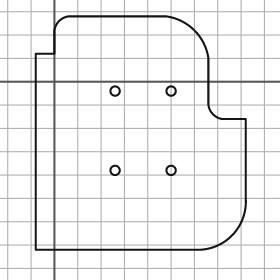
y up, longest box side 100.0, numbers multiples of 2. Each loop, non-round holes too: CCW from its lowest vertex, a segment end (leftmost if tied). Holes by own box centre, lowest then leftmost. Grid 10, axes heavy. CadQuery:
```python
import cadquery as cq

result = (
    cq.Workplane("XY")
    .moveTo(-8.0, -72.0)
    .lineTo(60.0, -72.0)
    .threePointArc((76.0, -66.0), (82.0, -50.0))
    .lineTo(82.0, -16.0)
    .lineTo(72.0, -16.0)
    .threePointArc((68.0, -14.0), (66.0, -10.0))
    .lineTo(66.0, 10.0)
    .threePointArc((60.0, 22.0), (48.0, 28.0))
    .lineTo(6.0, 28.0)
    .threePointArc((2.0, 26.0), (0.0, 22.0))
    .lineTo(0.0, 12.0)
    .lineTo(-8.0, 12.0)
    .close()
    .moveTo(26.0, -38.0)
    .circle(2.0)
    .moveTo(50.0, -38.0)
    .circle(2.0)
    .moveTo(26.0, -4.0)
    .circle(2.0)
    .moveTo(50.0, -4.0)
    .circle(2.0)
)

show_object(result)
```